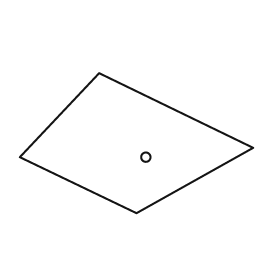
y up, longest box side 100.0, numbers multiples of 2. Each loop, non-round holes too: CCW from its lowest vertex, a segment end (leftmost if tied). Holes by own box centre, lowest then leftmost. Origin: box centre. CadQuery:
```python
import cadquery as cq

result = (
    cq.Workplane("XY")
    .moveTo(0.0, -30.0)
    .lineTo(50.0, -2.0)
    .lineTo(-16.0, 30.0)
    .lineTo(-50.0, -6.0)
    .close()
    .moveTo(4.0, -6.0)
    .circle(2.0)
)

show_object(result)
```